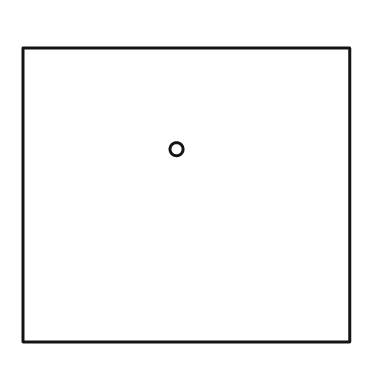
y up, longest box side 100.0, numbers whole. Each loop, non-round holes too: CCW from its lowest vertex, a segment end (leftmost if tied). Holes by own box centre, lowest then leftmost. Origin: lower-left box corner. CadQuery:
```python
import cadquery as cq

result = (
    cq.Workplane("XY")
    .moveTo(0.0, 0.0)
    .lineTo(100.0, 0.0)
    .lineTo(100.0, 90.0)
    .lineTo(0.0, 90.0)
    .close()
    .moveTo(47.0, 59.0)
    .circle(2.0)
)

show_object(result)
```